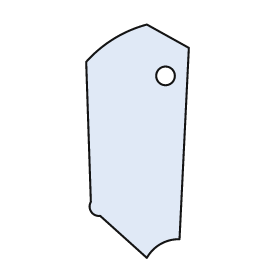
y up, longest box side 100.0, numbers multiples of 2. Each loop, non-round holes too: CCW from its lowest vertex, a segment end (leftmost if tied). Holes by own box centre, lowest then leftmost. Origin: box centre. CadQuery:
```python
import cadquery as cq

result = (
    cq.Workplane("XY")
    .moveTo(4.0, -50.0)
    .threePointArc((10.0, -44.0), (18.0, -42.0))
    .lineTo(22.0, 40.0)
    .lineTo(4.0, 50.0)
    .threePointArc((-10.0, 44.0), (-22.0, 34.0))
    .lineTo(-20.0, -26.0)
    .threePointArc((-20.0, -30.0), (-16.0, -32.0))
    .close()
    .moveTo(12.0, 28.0)
    .circle(4.0)
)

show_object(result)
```